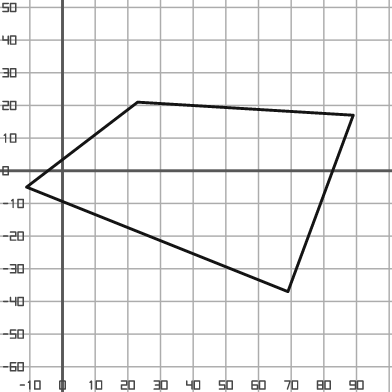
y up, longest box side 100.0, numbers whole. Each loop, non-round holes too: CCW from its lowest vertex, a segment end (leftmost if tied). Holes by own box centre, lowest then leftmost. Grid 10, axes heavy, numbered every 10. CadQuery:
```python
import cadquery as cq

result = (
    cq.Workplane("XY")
    .moveTo(69.0, -37.0)
    .lineTo(89.0, 17.0)
    .lineTo(23.0, 21.0)
    .lineTo(-11.0, -5.0)
    .close()
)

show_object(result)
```